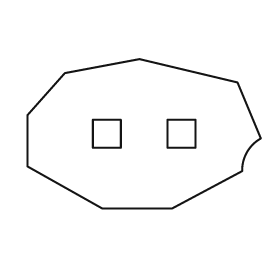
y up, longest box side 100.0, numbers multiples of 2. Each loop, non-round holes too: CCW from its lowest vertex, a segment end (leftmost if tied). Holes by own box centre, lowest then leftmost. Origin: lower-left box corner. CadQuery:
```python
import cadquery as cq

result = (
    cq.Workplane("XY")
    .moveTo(32.0, 0.0)
    .lineTo(62.0, 0.0)
    .lineTo(92.0, 16.0)
    .threePointArc((94.0, 24.0), (100.0, 30.0))
    .lineTo(90.0, 54.0)
    .lineTo(48.0, 64.0)
    .lineTo(16.0, 58.0)
    .lineTo(0.0, 40.0)
    .lineTo(0.0, 18.0)
    .close()
    .moveTo(28.0, 26.0)
    .lineTo(40.0, 26.0)
    .lineTo(40.0, 38.0)
    .lineTo(28.0, 38.0)
    .close()
    .moveTo(60.0, 26.0)
    .lineTo(72.0, 26.0)
    .lineTo(72.0, 38.0)
    .lineTo(60.0, 38.0)
    .close()
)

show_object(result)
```